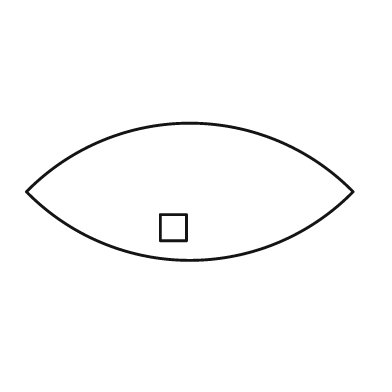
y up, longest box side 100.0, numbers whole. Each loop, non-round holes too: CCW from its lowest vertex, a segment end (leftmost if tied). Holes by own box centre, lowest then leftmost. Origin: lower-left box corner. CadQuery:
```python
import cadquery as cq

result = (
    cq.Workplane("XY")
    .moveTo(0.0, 21.0)
    .threePointArc((50.0, 0.0), (100.0, 21.0))
    .threePointArc((50.0, 42.0), (0.0, 21.0))
    .close()
    .moveTo(41.0, 6.0)
    .lineTo(49.0, 6.0)
    .lineTo(49.0, 14.0)
    .lineTo(41.0, 14.0)
    .close()
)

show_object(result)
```